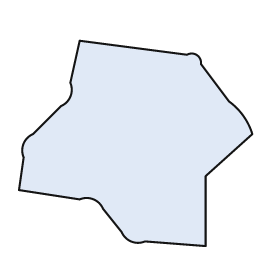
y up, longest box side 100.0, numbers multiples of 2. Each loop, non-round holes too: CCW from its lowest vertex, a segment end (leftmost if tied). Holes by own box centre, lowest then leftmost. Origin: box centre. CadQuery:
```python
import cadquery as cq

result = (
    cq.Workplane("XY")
    .moveTo(30.0, -44.0)
    .lineTo(30.0, -14.0)
    .lineTo(50.0, 4.0)
    .threePointArc((46.0, 12.0), (40.0, 18.0))
    .lineTo(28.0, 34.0)
    .threePointArc((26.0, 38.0), (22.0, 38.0))
    .lineTo(-24.0, 44.0)
    .lineTo(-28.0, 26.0)
    .threePointArc((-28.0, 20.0), (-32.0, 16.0))
    .lineTo(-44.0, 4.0)
    .threePointArc((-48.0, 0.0), (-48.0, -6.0))
    .lineTo(-50.0, -20.0)
    .lineTo(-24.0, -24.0)
    .threePointArc((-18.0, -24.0), (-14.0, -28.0))
    .lineTo(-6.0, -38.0)
    .threePointArc((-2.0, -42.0), (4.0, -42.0))
    .close()
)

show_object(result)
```